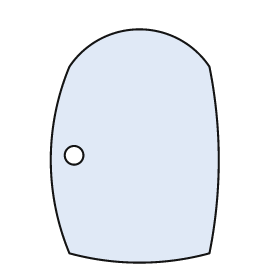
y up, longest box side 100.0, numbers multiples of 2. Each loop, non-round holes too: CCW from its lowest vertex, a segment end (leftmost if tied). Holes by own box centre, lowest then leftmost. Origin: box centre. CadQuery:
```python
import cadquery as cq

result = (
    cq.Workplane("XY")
    .moveTo(-28.0, -46.0)
    .threePointArc((2.0, -50.0), (32.0, -46.0))
    .threePointArc((36.0, -6.0), (32.0, 34.0))
    .threePointArc((2.0, 50.0), (-28.0, 34.0))
    .threePointArc((-36.0, -6.0), (-28.0, -46.0))
    .close()
    .moveTo(-26.0, -4.0)
    .circle(4.0)
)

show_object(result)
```